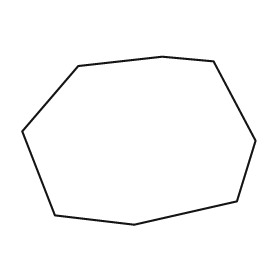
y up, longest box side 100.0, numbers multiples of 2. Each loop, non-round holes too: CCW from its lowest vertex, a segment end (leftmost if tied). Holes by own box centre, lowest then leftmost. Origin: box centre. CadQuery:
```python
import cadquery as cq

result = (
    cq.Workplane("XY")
    .moveTo(-2.0, -36.0)
    .lineTo(42.0, -26.0)
    .lineTo(50.0, 0.0)
    .lineTo(32.0, 34.0)
    .lineTo(10.0, 36.0)
    .lineTo(-26.0, 32.0)
    .lineTo(-50.0, 4.0)
    .lineTo(-36.0, -32.0)
    .close()
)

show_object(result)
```